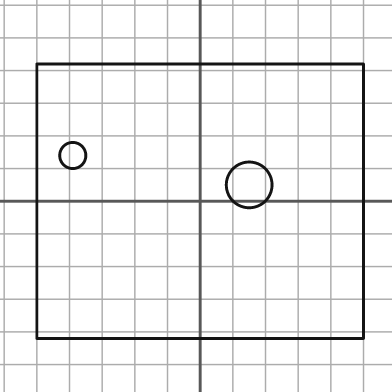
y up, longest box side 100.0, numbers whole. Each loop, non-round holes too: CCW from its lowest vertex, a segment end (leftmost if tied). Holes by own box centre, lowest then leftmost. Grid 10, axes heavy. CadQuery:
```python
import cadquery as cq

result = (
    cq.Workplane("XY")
    .moveTo(-50.0, -42.0)
    .lineTo(50.0, -42.0)
    .lineTo(50.0, 42.0)
    .lineTo(-50.0, 42.0)
    .close()
    .moveTo(15.0, 5.0)
    .circle(7.0)
    .moveTo(-39.0, 14.0)
    .circle(4.0)
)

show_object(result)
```